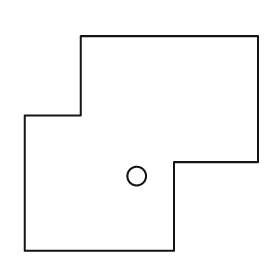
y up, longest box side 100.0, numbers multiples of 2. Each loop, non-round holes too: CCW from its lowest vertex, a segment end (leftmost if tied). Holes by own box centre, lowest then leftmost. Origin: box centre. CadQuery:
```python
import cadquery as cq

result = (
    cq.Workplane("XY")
    .moveTo(-50.0, -46.0)
    .lineTo(14.0, -46.0)
    .lineTo(14.0, -8.0)
    .lineTo(50.0, -8.0)
    .lineTo(50.0, 46.0)
    .lineTo(-26.0, 46.0)
    .lineTo(-26.0, 12.0)
    .lineTo(-50.0, 12.0)
    .close()
    .moveTo(-2.0, -14.0)
    .circle(4.0)
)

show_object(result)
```